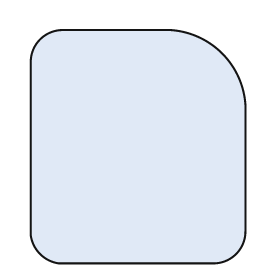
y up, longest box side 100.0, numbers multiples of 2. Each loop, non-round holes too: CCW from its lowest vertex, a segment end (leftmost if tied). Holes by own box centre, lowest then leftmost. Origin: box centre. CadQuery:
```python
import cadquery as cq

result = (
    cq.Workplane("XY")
    .moveTo(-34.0, -50.0)
    .lineTo(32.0, -50.0)
    .threePointArc((42.0, -46.0), (46.0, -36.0))
    .lineTo(46.0, 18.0)
    .threePointArc((36.0, 40.0), (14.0, 50.0))
    .lineTo(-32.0, 50.0)
    .threePointArc((-42.0, 46.0), (-46.0, 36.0))
    .lineTo(-46.0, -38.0)
    .threePointArc((-42.0, -46.0), (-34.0, -50.0))
    .close()
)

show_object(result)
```